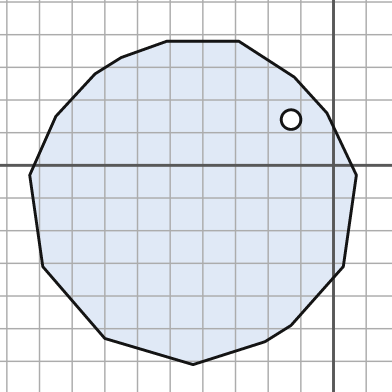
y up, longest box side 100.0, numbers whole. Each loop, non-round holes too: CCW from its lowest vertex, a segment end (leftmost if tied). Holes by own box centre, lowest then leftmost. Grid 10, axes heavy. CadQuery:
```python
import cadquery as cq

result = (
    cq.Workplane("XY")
    .moveTo(-43.0, -61.0)
    .lineTo(-21.0, -54.0)
    .lineTo(-13.0, -49.0)
    .lineTo(3.0, -31.0)
    .lineTo(7.0, -3.0)
    .lineTo(-2.0, 16.0)
    .lineTo(-12.0, 27.0)
    .lineTo(-29.0, 38.0)
    .lineTo(-51.0, 38.0)
    .lineTo(-65.0, 33.0)
    .lineTo(-73.0, 28.0)
    .lineTo(-85.0, 15.0)
    .lineTo(-93.0, -3.0)
    .lineTo(-89.0, -31.0)
    .lineTo(-70.0, -53.0)
    .close()
    .moveTo(-13.0, 14.0)
    .circle(3.0)
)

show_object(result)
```